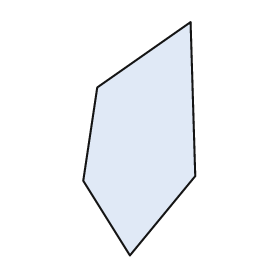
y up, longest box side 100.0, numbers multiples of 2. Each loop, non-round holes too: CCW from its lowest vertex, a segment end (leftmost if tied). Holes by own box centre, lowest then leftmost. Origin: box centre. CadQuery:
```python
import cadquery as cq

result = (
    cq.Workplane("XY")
    .moveTo(-4.0, -50.0)
    .lineTo(24.0, -16.0)
    .lineTo(22.0, 50.0)
    .lineTo(-18.0, 22.0)
    .lineTo(-24.0, -18.0)
    .close()
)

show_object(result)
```